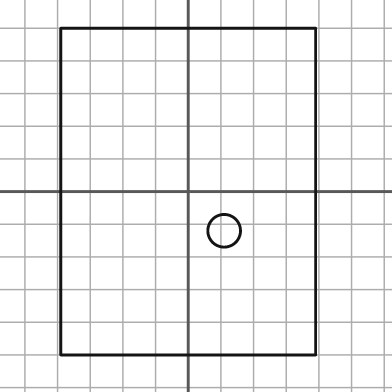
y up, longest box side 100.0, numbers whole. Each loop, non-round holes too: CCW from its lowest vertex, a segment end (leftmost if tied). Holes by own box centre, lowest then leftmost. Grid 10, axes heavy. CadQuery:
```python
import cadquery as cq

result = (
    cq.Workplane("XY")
    .moveTo(-39.0, -50.0)
    .lineTo(39.0, -50.0)
    .lineTo(39.0, 50.0)
    .lineTo(-39.0, 50.0)
    .close()
    .moveTo(11.0, -12.0)
    .circle(5.0)
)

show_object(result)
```